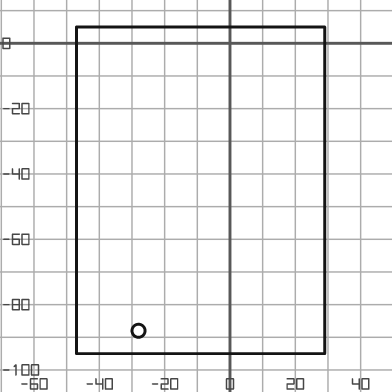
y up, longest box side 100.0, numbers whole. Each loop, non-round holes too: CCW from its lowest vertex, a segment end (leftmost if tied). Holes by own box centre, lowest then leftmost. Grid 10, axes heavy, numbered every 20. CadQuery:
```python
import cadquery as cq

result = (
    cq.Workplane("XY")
    .moveTo(-47.0, -95.0)
    .lineTo(29.0, -95.0)
    .lineTo(29.0, 5.0)
    .lineTo(-47.0, 5.0)
    .close()
    .moveTo(-28.0, -88.0)
    .circle(2.0)
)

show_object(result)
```